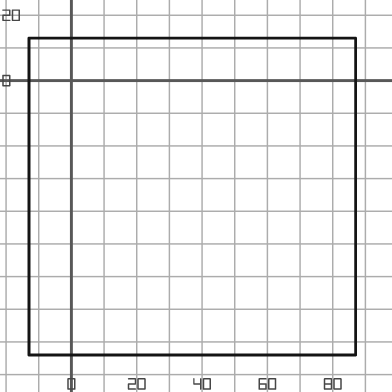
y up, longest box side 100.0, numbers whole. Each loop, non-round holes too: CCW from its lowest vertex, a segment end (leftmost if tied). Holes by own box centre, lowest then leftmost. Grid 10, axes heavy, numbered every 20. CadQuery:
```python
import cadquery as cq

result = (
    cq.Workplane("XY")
    .moveTo(-13.0, -84.0)
    .lineTo(87.0, -84.0)
    .lineTo(87.0, 13.0)
    .lineTo(-13.0, 13.0)
    .close()
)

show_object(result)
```